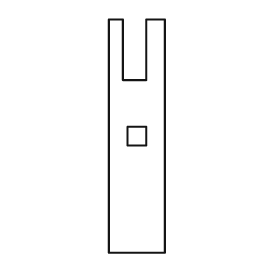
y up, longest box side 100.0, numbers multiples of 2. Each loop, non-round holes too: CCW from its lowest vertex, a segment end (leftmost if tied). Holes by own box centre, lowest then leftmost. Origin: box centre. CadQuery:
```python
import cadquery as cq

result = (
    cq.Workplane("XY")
    .moveTo(-12.0, -50.0)
    .lineTo(12.0, -50.0)
    .lineTo(12.0, 50.0)
    .lineTo(4.0, 50.0)
    .lineTo(4.0, 24.0)
    .lineTo(-6.0, 24.0)
    .lineTo(-6.0, 50.0)
    .lineTo(-12.0, 50.0)
    .close()
    .moveTo(-4.0, -4.0)
    .lineTo(4.0, -4.0)
    .lineTo(4.0, 4.0)
    .lineTo(-4.0, 4.0)
    .close()
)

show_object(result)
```